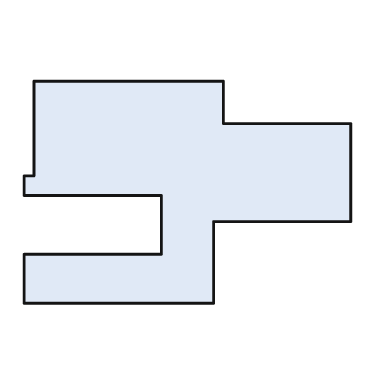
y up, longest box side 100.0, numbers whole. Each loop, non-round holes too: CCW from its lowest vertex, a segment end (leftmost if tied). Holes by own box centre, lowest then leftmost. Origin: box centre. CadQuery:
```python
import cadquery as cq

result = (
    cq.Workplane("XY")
    .moveTo(-50.0, -34.0)
    .lineTo(8.0, -34.0)
    .lineTo(8.0, -9.0)
    .lineTo(50.0, -9.0)
    .lineTo(50.0, 21.0)
    .lineTo(11.0, 21.0)
    .lineTo(11.0, 34.0)
    .lineTo(-47.0, 34.0)
    .lineTo(-47.0, 5.0)
    .lineTo(-50.0, 5.0)
    .lineTo(-50.0, -1.0)
    .lineTo(-8.0, -1.0)
    .lineTo(-8.0, -19.0)
    .lineTo(-50.0, -19.0)
    .close()
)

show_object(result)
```